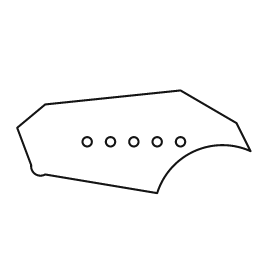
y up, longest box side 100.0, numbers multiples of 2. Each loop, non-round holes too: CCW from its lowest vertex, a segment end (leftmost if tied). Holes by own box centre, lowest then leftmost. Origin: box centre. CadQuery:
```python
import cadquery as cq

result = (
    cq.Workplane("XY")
    .moveTo(10.0, -22.0)
    .threePointArc((26.0, -4.0), (50.0, -4.0))
    .lineTo(44.0, 8.0)
    .lineTo(20.0, 22.0)
    .lineTo(-38.0, 16.0)
    .lineTo(-50.0, 6.0)
    .lineTo(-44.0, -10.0)
    .threePointArc((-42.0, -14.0), (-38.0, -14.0))
    .close()
    .moveTo(-20.0, 0.0)
    .circle(2.0)
    .moveTo(-10.0, 0.0)
    .circle(2.0)
    .moveTo(0.0, 0.0)
    .circle(2.0)
    .moveTo(10.0, 0.0)
    .circle(2.0)
    .moveTo(20.0, 0.0)
    .circle(2.0)
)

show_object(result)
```